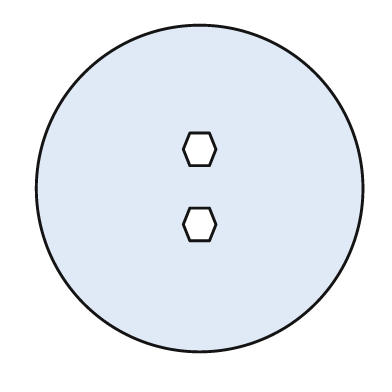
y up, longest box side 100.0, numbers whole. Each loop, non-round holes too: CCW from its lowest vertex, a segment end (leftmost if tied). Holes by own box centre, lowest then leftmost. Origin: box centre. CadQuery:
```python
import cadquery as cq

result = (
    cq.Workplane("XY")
    .moveTo(0.0, 0.0)
    .circle(50.0)
    .moveTo(-3.0, -16.0)
    .lineTo(3.0, -16.0)
    .lineTo(5.0, -11.0)
    .lineTo(3.0, -6.0)
    .lineTo(-3.0, -6.0)
    .lineTo(-5.0, -11.0)
    .close()
    .moveTo(-3.0, 7.0)
    .lineTo(3.0, 7.0)
    .lineTo(5.0, 12.0)
    .lineTo(3.0, 17.0)
    .lineTo(-3.0, 17.0)
    .lineTo(-5.0, 12.0)
    .close()
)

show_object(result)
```